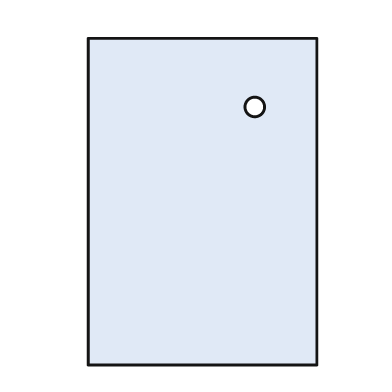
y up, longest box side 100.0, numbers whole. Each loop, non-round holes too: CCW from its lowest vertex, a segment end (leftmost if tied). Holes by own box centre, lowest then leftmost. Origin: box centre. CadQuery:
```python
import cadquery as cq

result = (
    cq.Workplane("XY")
    .moveTo(-35.0, -50.0)
    .lineTo(35.0, -50.0)
    .lineTo(35.0, 50.0)
    .lineTo(-35.0, 50.0)
    .close()
    .moveTo(16.0, 29.0)
    .circle(3.0)
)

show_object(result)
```